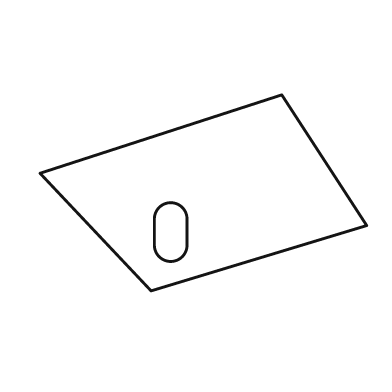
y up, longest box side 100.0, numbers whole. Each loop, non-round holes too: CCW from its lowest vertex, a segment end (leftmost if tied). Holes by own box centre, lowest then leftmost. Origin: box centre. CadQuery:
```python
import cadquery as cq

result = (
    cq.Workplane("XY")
    .moveTo(-16.0, -30.0)
    .lineTo(50.0, -10.0)
    .lineTo(24.0, 30.0)
    .lineTo(-50.0, 6.0)
    .close()
    .moveTo(-15.0, -16.0)
    .threePointArc((-10.0, -21.0), (-5.0, -16.0))
    .lineTo(-5.0, -8.0)
    .threePointArc((-10.0, -3.0), (-15.0, -8.0))
    .close()
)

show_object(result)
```